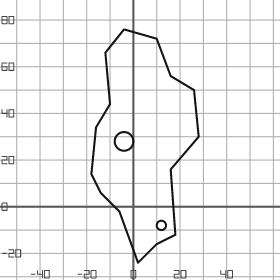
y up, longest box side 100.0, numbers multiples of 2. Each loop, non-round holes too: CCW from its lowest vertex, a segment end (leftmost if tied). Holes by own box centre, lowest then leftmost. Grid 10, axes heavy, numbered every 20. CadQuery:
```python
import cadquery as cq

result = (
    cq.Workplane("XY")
    .moveTo(2.0, -24.0)
    .lineTo(10.0, -16.0)
    .lineTo(18.0, -12.0)
    .lineTo(16.0, 16.0)
    .lineTo(28.0, 30.0)
    .lineTo(26.0, 50.0)
    .lineTo(16.0, 56.0)
    .lineTo(10.0, 72.0)
    .lineTo(-4.0, 76.0)
    .lineTo(-12.0, 66.0)
    .lineTo(-10.0, 44.0)
    .lineTo(-16.0, 34.0)
    .lineTo(-18.0, 14.0)
    .lineTo(-14.0, 6.0)
    .lineTo(-6.0, -2.0)
    .close()
    .moveTo(12.0, -8.0)
    .circle(2.0)
    .moveTo(-4.0, 28.0)
    .circle(4.0)
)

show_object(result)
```